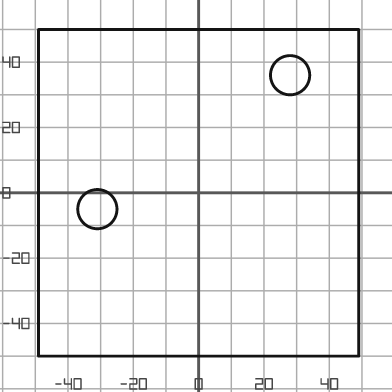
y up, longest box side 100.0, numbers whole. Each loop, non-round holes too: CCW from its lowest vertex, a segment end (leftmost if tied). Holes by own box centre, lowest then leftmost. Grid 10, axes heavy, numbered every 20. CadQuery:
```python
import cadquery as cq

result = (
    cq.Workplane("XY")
    .moveTo(-49.0, -50.0)
    .lineTo(49.0, -50.0)
    .lineTo(49.0, 50.0)
    .lineTo(-49.0, 50.0)
    .close()
    .moveTo(-31.0, -5.0)
    .circle(6.0)
    .moveTo(28.0, 36.0)
    .circle(6.0)
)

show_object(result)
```